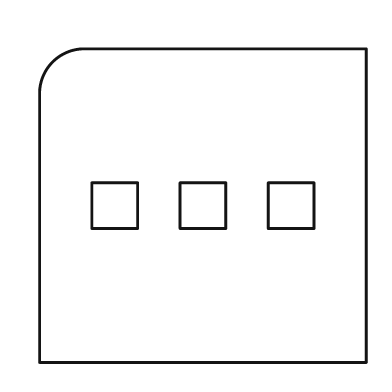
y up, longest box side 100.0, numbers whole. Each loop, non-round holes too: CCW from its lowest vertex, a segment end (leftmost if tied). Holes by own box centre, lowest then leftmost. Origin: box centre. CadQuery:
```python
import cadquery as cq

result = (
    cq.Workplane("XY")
    .moveTo(-50.0, -48.0)
    .lineTo(50.0, -48.0)
    .lineTo(50.0, 48.0)
    .lineTo(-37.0, 48.0)
    .threePointArc((-46.0, 44.0), (-50.0, 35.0))
    .close()
    .moveTo(-34.0, -7.0)
    .lineTo(-20.0, -7.0)
    .lineTo(-20.0, 7.0)
    .lineTo(-34.0, 7.0)
    .close()
    .moveTo(-7.0, -7.0)
    .lineTo(7.0, -7.0)
    .lineTo(7.0, 7.0)
    .lineTo(-7.0, 7.0)
    .close()
    .moveTo(20.0, -7.0)
    .lineTo(34.0, -7.0)
    .lineTo(34.0, 7.0)
    .lineTo(20.0, 7.0)
    .close()
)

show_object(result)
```